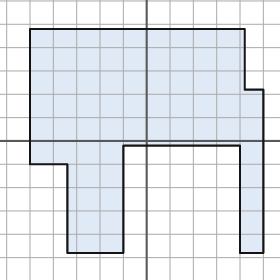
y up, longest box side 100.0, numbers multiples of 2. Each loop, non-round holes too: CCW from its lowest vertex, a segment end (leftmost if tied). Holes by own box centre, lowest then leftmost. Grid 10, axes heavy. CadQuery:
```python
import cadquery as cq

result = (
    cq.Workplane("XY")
    .moveTo(-34.0, -48.0)
    .lineTo(-10.0, -48.0)
    .lineTo(-10.0, -2.0)
    .lineTo(40.0, -2.0)
    .lineTo(40.0, -48.0)
    .lineTo(50.0, -48.0)
    .lineTo(50.0, 22.0)
    .lineTo(42.0, 22.0)
    .lineTo(42.0, 48.0)
    .lineTo(-50.0, 48.0)
    .lineTo(-50.0, -10.0)
    .lineTo(-34.0, -10.0)
    .close()
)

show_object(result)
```